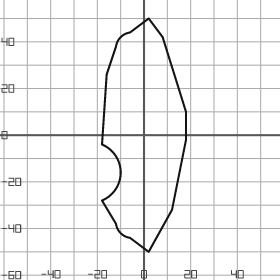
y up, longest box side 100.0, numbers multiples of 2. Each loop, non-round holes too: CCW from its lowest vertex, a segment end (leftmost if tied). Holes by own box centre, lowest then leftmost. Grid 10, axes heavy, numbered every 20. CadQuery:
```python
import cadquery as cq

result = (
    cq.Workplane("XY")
    .moveTo(2.0, -50.0)
    .lineTo(12.0, -32.0)
    .lineTo(18.0, -2.0)
    .lineTo(18.0, 10.0)
    .lineTo(8.0, 42.0)
    .lineTo(2.0, 50.0)
    .lineTo(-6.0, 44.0)
    .threePointArc((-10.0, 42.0), (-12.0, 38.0))
    .lineTo(-16.0, 26.0)
    .lineTo(-18.0, -4.0)
    .threePointArc((-10.0, -16.0), (-18.0, -28.0))
    .lineTo(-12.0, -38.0)
    .threePointArc((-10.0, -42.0), (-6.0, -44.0))
    .close()
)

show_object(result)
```